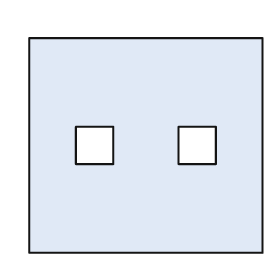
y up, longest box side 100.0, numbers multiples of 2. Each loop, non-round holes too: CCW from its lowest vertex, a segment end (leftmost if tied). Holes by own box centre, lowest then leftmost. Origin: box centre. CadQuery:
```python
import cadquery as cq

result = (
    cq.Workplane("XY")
    .moveTo(-50.0, -46.0)
    .lineTo(50.0, -46.0)
    .lineTo(50.0, 46.0)
    .lineTo(-50.0, 46.0)
    .close()
    .moveTo(-30.0, -8.0)
    .lineTo(-14.0, -8.0)
    .lineTo(-14.0, 8.0)
    .lineTo(-30.0, 8.0)
    .close()
    .moveTo(14.0, -8.0)
    .lineTo(30.0, -8.0)
    .lineTo(30.0, 8.0)
    .lineTo(14.0, 8.0)
    .close()
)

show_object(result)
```